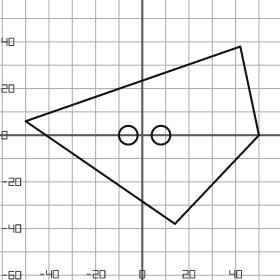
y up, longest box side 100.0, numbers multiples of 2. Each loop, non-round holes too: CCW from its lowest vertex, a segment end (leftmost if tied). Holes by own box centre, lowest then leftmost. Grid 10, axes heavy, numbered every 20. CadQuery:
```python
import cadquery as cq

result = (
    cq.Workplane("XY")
    .moveTo(14.0, -38.0)
    .lineTo(50.0, 0.0)
    .lineTo(42.0, 38.0)
    .lineTo(-50.0, 6.0)
    .close()
    .moveTo(-6.0, 0.0)
    .circle(4.0)
    .moveTo(8.0, 0.0)
    .circle(4.0)
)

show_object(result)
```